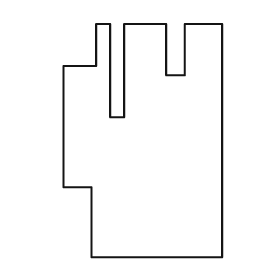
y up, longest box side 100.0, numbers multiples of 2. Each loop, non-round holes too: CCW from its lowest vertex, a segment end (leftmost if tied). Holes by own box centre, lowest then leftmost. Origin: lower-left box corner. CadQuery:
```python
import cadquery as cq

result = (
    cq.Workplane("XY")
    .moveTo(12.0, 0.0)
    .lineTo(68.0, 0.0)
    .lineTo(68.0, 100.0)
    .lineTo(52.0, 100.0)
    .lineTo(52.0, 78.0)
    .lineTo(44.0, 78.0)
    .lineTo(44.0, 100.0)
    .lineTo(26.0, 100.0)
    .lineTo(26.0, 60.0)
    .lineTo(20.0, 60.0)
    .lineTo(20.0, 100.0)
    .lineTo(14.0, 100.0)
    .lineTo(14.0, 82.0)
    .lineTo(0.0, 82.0)
    .lineTo(0.0, 30.0)
    .lineTo(12.0, 30.0)
    .close()
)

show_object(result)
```